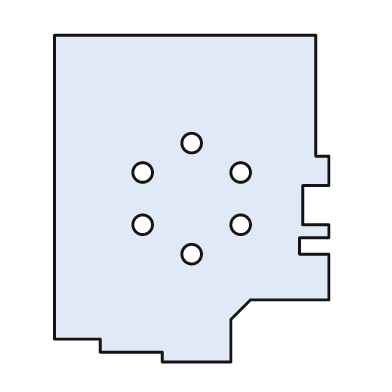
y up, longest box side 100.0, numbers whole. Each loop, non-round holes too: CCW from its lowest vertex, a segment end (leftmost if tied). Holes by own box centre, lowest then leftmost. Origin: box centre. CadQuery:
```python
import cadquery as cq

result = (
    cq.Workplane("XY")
    .moveTo(-9.0, -50.0)
    .lineTo(12.0, -50.0)
    .lineTo(12.0, -37.0)
    .lineTo(18.0, -31.0)
    .lineTo(42.0, -31.0)
    .lineTo(42.0, -17.0)
    .lineTo(33.0, -17.0)
    .lineTo(33.0, -12.0)
    .lineTo(42.0, -12.0)
    .lineTo(42.0, -8.0)
    .lineTo(34.0, -8.0)
    .lineTo(34.0, 4.0)
    .lineTo(42.0, 4.0)
    .lineTo(42.0, 13.0)
    .lineTo(38.0, 13.0)
    .lineTo(38.0, 50.0)
    .lineTo(-42.0, 50.0)
    .lineTo(-42.0, -43.0)
    .lineTo(-28.0, -43.0)
    .lineTo(-28.0, -47.0)
    .lineTo(-9.0, -47.0)
    .close()
    .moveTo(0.0, -17.0)
    .circle(3.0)
    .moveTo(-15.0, -8.0)
    .circle(3.0)
    .moveTo(15.0, -8.0)
    .circle(3.0)
    .moveTo(-15.0, 8.0)
    .circle(3.0)
    .moveTo(15.0, 8.0)
    .circle(3.0)
    .moveTo(0.0, 17.0)
    .circle(3.0)
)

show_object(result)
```